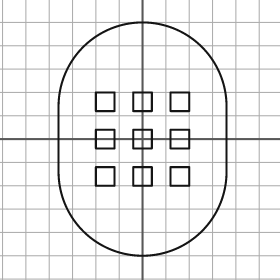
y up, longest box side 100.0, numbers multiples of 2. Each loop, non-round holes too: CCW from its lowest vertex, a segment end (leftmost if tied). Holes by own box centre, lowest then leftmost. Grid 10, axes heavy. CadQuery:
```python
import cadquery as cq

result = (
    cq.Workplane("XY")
    .moveTo(-36.0, -14.0)
    .threePointArc((0.0, -50.0), (36.0, -14.0))
    .lineTo(36.0, 14.0)
    .threePointArc((0.0, 50.0), (-36.0, 14.0))
    .close()
    .moveTo(-20.0, -20.0)
    .lineTo(-12.0, -20.0)
    .lineTo(-12.0, -12.0)
    .lineTo(-20.0, -12.0)
    .close()
    .moveTo(-4.0, -20.0)
    .lineTo(4.0, -20.0)
    .lineTo(4.0, -12.0)
    .lineTo(-4.0, -12.0)
    .close()
    .moveTo(12.0, -20.0)
    .lineTo(20.0, -20.0)
    .lineTo(20.0, -12.0)
    .lineTo(12.0, -12.0)
    .close()
    .moveTo(-20.0, -4.0)
    .lineTo(-12.0, -4.0)
    .lineTo(-12.0, 4.0)
    .lineTo(-20.0, 4.0)
    .close()
    .moveTo(-4.0, -4.0)
    .lineTo(4.0, -4.0)
    .lineTo(4.0, 4.0)
    .lineTo(-4.0, 4.0)
    .close()
    .moveTo(12.0, -4.0)
    .lineTo(20.0, -4.0)
    .lineTo(20.0, 4.0)
    .lineTo(12.0, 4.0)
    .close()
    .moveTo(-20.0, 12.0)
    .lineTo(-12.0, 12.0)
    .lineTo(-12.0, 20.0)
    .lineTo(-20.0, 20.0)
    .close()
    .moveTo(-4.0, 12.0)
    .lineTo(4.0, 12.0)
    .lineTo(4.0, 20.0)
    .lineTo(-4.0, 20.0)
    .close()
    .moveTo(12.0, 12.0)
    .lineTo(20.0, 12.0)
    .lineTo(20.0, 20.0)
    .lineTo(12.0, 20.0)
    .close()
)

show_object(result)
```